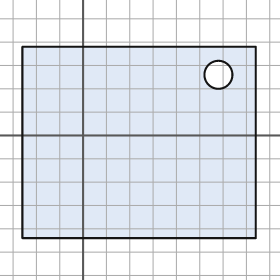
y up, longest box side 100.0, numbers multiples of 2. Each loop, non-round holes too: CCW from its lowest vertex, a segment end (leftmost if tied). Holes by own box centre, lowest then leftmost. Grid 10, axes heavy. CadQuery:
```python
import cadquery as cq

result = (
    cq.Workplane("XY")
    .moveTo(-26.0, -44.0)
    .lineTo(74.0, -44.0)
    .lineTo(74.0, 38.0)
    .lineTo(-26.0, 38.0)
    .close()
    .moveTo(58.0, 26.0)
    .circle(6.0)
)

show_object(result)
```